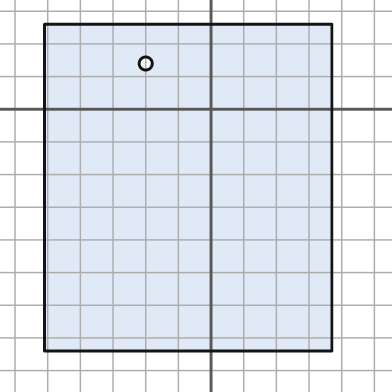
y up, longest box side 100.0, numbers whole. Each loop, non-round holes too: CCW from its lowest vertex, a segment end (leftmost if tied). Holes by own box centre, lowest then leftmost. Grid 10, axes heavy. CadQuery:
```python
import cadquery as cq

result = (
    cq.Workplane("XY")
    .moveTo(-51.0, -74.0)
    .lineTo(37.0, -74.0)
    .lineTo(37.0, 26.0)
    .lineTo(-51.0, 26.0)
    .close()
    .moveTo(-20.0, 14.0)
    .circle(2.0)
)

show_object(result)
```